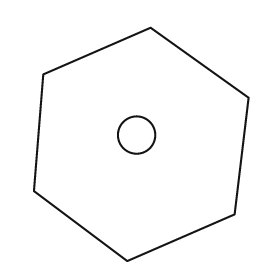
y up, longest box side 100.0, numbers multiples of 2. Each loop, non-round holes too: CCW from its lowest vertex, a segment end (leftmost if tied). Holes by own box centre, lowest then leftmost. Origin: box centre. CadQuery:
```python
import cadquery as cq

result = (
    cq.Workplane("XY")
    .moveTo(-6.0, -50.0)
    .lineTo(40.0, -30.0)
    .lineTo(46.0, 20.0)
    .lineTo(4.0, 50.0)
    .lineTo(-42.0, 30.0)
    .lineTo(-46.0, -20.0)
    .close()
    .moveTo(-2.0, 4.0)
    .circle(8.0)
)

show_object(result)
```